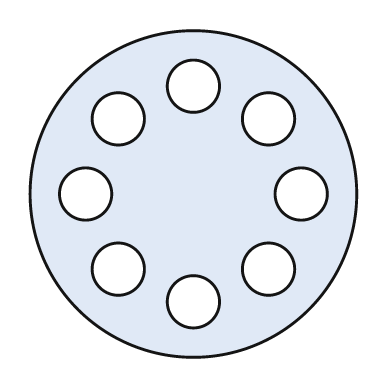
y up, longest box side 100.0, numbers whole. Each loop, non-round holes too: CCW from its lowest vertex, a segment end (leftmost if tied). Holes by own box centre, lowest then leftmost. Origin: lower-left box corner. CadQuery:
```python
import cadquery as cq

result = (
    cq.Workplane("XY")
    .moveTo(50.0, 50.0)
    .circle(50.0)
    .moveTo(50.0, 17.0)
    .circle(8.0)
    .moveTo(27.0, 27.0)
    .circle(8.0)
    .moveTo(73.0, 27.0)
    .circle(8.0)
    .moveTo(17.0, 50.0)
    .circle(8.0)
    .moveTo(83.0, 50.0)
    .circle(8.0)
    .moveTo(27.0, 73.0)
    .circle(8.0)
    .moveTo(73.0, 73.0)
    .circle(8.0)
    .moveTo(50.0, 83.0)
    .circle(8.0)
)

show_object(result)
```